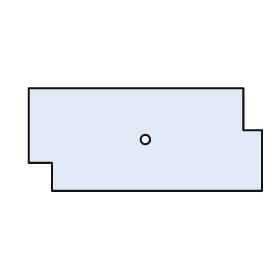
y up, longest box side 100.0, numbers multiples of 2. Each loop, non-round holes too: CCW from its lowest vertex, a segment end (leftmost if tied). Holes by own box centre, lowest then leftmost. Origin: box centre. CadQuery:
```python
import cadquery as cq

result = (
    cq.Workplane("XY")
    .moveTo(-40.0, -22.0)
    .lineTo(50.0, -22.0)
    .lineTo(50.0, 4.0)
    .lineTo(42.0, 4.0)
    .lineTo(42.0, 22.0)
    .lineTo(-50.0, 22.0)
    .lineTo(-50.0, -10.0)
    .lineTo(-40.0, -10.0)
    .close()
    .moveTo(0.0, 0.0)
    .circle(2.0)
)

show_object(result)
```